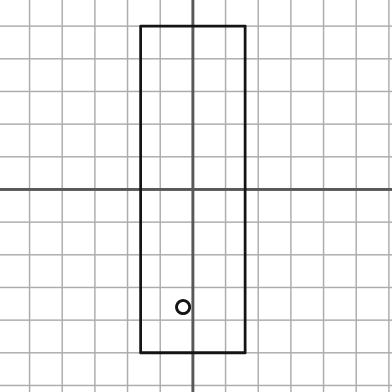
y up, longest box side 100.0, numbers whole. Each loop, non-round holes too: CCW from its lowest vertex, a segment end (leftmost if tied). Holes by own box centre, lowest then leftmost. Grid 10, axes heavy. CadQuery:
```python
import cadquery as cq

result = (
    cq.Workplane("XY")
    .moveTo(-16.0, -50.0)
    .lineTo(16.0, -50.0)
    .lineTo(16.0, 50.0)
    .lineTo(-16.0, 50.0)
    .close()
    .moveTo(-3.0, -36.0)
    .circle(2.0)
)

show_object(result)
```